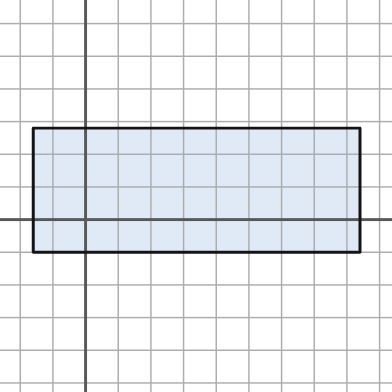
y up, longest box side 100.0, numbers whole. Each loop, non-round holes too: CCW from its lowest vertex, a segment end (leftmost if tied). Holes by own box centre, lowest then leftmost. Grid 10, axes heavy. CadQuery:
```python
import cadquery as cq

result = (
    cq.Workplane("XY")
    .moveTo(-16.0, -10.0)
    .lineTo(84.0, -10.0)
    .lineTo(84.0, 28.0)
    .lineTo(-16.0, 28.0)
    .close()
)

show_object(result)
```